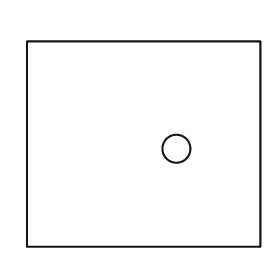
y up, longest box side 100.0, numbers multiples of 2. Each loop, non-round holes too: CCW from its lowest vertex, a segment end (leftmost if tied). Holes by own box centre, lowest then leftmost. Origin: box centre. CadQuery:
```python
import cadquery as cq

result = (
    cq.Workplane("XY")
    .moveTo(-50.0, -44.0)
    .lineTo(50.0, -44.0)
    .lineTo(50.0, 44.0)
    .lineTo(-50.0, 44.0)
    .close()
    .moveTo(14.0, -2.0)
    .circle(6.0)
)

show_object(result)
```